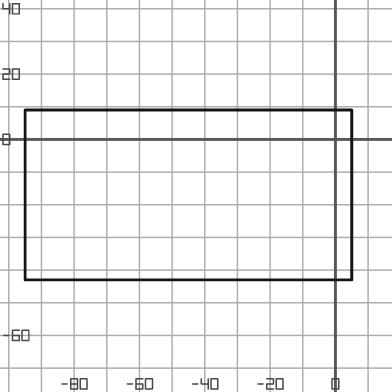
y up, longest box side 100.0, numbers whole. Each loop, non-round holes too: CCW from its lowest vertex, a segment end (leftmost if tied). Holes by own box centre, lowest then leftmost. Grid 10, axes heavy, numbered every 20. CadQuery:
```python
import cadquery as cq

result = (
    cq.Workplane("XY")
    .moveTo(-95.0, -43.0)
    .lineTo(5.0, -43.0)
    .lineTo(5.0, 9.0)
    .lineTo(-95.0, 9.0)
    .close()
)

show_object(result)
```